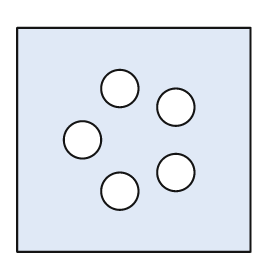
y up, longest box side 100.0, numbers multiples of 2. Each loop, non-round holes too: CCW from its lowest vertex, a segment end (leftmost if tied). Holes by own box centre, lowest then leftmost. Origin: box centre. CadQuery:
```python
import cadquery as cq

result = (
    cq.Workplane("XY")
    .moveTo(-50.0, -48.0)
    .lineTo(50.0, -48.0)
    .lineTo(50.0, 48.0)
    .lineTo(-50.0, 48.0)
    .close()
    .moveTo(-6.0, -22.0)
    .circle(8.0)
    .moveTo(18.0, -14.0)
    .circle(8.0)
    .moveTo(-22.0, 0.0)
    .circle(8.0)
    .moveTo(18.0, 14.0)
    .circle(8.0)
    .moveTo(-6.0, 22.0)
    .circle(8.0)
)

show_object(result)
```